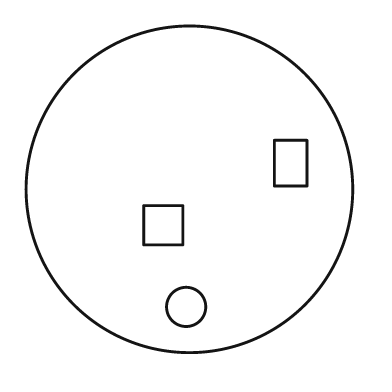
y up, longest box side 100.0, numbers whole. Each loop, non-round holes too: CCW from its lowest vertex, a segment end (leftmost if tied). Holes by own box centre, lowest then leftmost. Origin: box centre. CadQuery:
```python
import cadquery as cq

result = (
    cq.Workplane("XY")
    .moveTo(0.0, 0.0)
    .circle(50.0)
    .moveTo(-1.0, -36.0)
    .circle(6.0)
    .moveTo(-14.0, -17.0)
    .lineTo(-2.0, -17.0)
    .lineTo(-2.0, -5.0)
    .lineTo(-14.0, -5.0)
    .close()
    .moveTo(26.0, 1.0)
    .lineTo(36.0, 1.0)
    .lineTo(36.0, 15.0)
    .lineTo(26.0, 15.0)
    .close()
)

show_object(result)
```